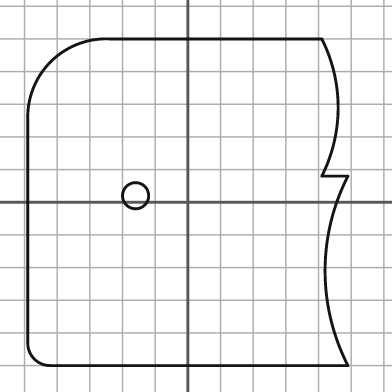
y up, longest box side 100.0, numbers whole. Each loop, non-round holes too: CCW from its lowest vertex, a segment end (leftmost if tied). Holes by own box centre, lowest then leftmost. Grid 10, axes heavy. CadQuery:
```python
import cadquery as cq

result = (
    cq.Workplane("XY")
    .moveTo(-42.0, -50.0)
    .lineTo(49.0, -50.0)
    .threePointArc((42.0, -21.0), (49.0, 8.0))
    .lineTo(41.0, 8.0)
    .threePointArc((46.0, 29.0), (41.0, 50.0))
    .lineTo(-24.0, 50.0)
    .threePointArc((-42.0, 43.0), (-49.0, 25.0))
    .lineTo(-49.0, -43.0)
    .threePointArc((-47.0, -48.0), (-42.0, -50.0))
    .close()
    .moveTo(-16.0, 2.0)
    .circle(4.0)
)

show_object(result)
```